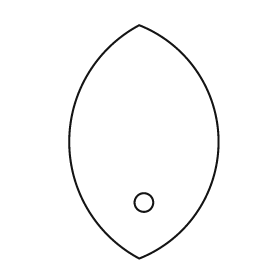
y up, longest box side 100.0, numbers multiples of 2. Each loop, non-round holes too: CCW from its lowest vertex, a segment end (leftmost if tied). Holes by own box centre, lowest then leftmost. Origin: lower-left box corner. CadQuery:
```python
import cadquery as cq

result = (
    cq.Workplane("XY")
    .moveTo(30.0, 0.0)
    .threePointArc((64.0, 50.0), (30.0, 100.0))
    .threePointArc((0.0, 50.0), (30.0, 0.0))
    .close()
    .moveTo(32.0, 24.0)
    .circle(4.0)
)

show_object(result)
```